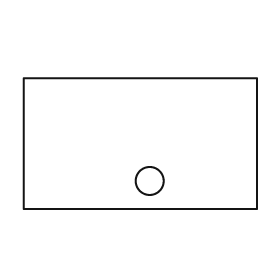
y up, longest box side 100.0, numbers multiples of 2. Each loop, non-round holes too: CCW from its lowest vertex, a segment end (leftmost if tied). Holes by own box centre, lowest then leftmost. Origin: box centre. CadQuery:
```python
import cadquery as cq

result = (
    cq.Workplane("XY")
    .moveTo(-50.0, -28.0)
    .lineTo(50.0, -28.0)
    .lineTo(50.0, 28.0)
    .lineTo(-50.0, 28.0)
    .close()
    .moveTo(4.0, -16.0)
    .circle(6.0)
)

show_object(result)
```